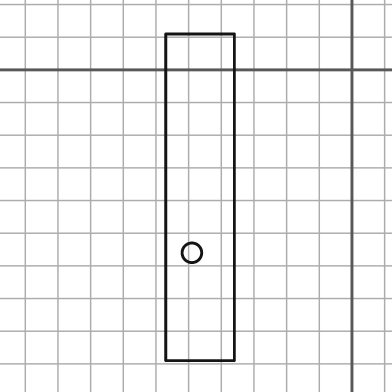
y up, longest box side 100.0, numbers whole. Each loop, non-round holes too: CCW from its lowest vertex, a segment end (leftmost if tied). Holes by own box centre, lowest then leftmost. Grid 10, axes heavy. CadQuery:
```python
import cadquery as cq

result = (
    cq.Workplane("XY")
    .moveTo(-57.0, -89.0)
    .lineTo(-36.0, -89.0)
    .lineTo(-36.0, 11.0)
    .lineTo(-57.0, 11.0)
    .close()
    .moveTo(-49.0, -56.0)
    .circle(3.0)
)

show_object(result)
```